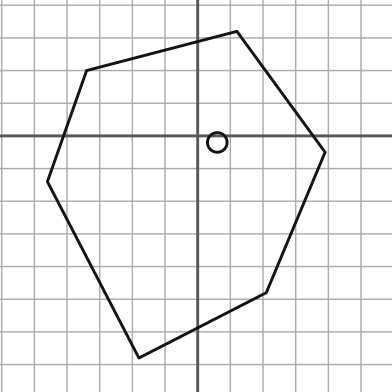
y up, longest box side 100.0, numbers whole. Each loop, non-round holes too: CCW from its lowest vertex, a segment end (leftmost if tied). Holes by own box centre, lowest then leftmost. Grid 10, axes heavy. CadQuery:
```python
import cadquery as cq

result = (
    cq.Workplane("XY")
    .moveTo(-18.0, -68.0)
    .lineTo(21.0, -48.0)
    .lineTo(39.0, -5.0)
    .lineTo(12.0, 32.0)
    .lineTo(-34.0, 20.0)
    .lineTo(-46.0, -14.0)
    .close()
    .moveTo(6.0, -2.0)
    .circle(3.0)
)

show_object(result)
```